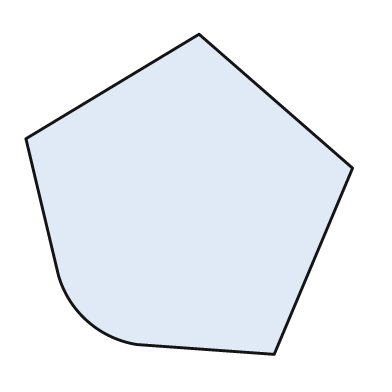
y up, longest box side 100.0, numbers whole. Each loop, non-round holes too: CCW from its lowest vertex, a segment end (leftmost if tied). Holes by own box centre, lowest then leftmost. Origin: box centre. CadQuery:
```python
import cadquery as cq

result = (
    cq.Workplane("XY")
    .moveTo(26.0, -49.0)
    .lineTo(50.0, 8.0)
    .lineTo(3.0, 49.0)
    .lineTo(-50.0, 17.0)
    .lineTo(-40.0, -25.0)
    .threePointArc((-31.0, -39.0), (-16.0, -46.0))
    .close()
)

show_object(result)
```